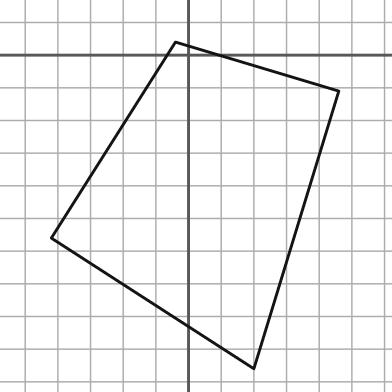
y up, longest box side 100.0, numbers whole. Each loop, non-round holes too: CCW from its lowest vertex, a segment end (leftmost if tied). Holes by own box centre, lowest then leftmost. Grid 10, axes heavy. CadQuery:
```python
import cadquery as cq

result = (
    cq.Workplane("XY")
    .moveTo(20.0, -96.0)
    .lineTo(46.0, -11.0)
    .lineTo(-4.0, 4.0)
    .lineTo(-42.0, -56.0)
    .close()
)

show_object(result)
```